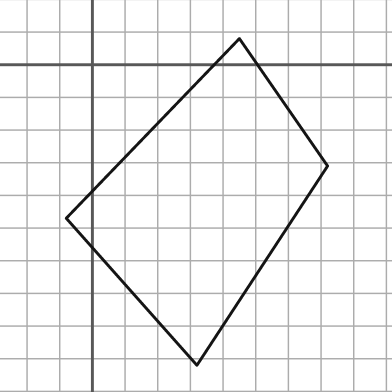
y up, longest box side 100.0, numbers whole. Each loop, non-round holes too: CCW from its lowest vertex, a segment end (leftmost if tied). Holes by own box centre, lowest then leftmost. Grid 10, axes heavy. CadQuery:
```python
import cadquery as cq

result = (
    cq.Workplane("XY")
    .moveTo(32.0, -92.0)
    .lineTo(72.0, -31.0)
    .lineTo(45.0, 8.0)
    .lineTo(-8.0, -47.0)
    .close()
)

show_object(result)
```